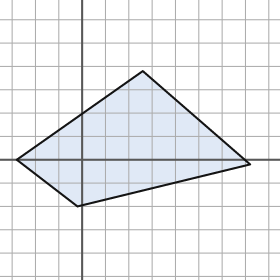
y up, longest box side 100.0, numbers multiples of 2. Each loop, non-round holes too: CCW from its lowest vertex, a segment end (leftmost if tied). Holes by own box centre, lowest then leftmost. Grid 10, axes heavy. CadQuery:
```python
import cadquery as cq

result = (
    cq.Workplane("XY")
    .moveTo(-2.0, -20.0)
    .lineTo(72.0, -2.0)
    .lineTo(26.0, 38.0)
    .lineTo(-28.0, 0.0)
    .close()
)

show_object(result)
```